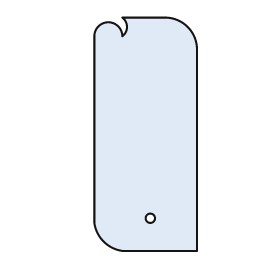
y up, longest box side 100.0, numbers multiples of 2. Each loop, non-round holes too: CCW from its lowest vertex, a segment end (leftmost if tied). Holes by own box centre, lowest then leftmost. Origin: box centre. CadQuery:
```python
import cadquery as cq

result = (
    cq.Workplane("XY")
    .moveTo(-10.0, -50.0)
    .lineTo(22.0, -50.0)
    .lineTo(22.0, 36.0)
    .threePointArc((18.0, 46.0), (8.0, 50.0))
    .lineTo(-10.0, 50.0)
    .threePointArc((-8.0, 46.0), (-10.0, 42.0))
    .threePointArc((-16.0, 48.0), (-22.0, 42.0))
    .lineTo(-22.0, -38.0)
    .threePointArc((-18.0, -46.0), (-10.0, -50.0))
    .close()
    .moveTo(2.0, -36.0)
    .circle(2.0)
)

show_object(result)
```